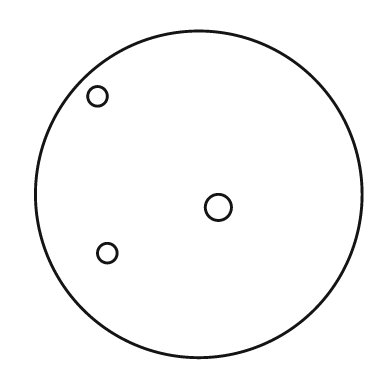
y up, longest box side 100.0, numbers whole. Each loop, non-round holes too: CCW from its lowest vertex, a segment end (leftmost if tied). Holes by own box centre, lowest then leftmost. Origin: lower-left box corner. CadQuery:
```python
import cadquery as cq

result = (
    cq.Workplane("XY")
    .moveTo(50.0, 50.0)
    .circle(50.0)
    .moveTo(22.0, 32.0)
    .circle(3.0)
    .moveTo(56.0, 46.0)
    .circle(4.0)
    .moveTo(19.0, 80.0)
    .circle(3.0)
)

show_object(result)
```